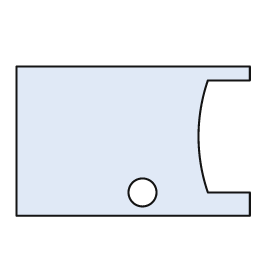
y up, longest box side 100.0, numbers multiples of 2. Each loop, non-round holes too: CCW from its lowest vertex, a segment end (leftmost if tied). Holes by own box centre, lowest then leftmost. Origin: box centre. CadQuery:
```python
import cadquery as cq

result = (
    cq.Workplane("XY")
    .moveTo(-50.0, -32.0)
    .lineTo(50.0, -32.0)
    .lineTo(50.0, -22.0)
    .lineTo(32.0, -22.0)
    .threePointArc((28.0, 2.0), (32.0, 26.0))
    .lineTo(50.0, 26.0)
    .lineTo(50.0, 32.0)
    .lineTo(-50.0, 32.0)
    .close()
    .moveTo(4.0, -22.0)
    .circle(6.0)
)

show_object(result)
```